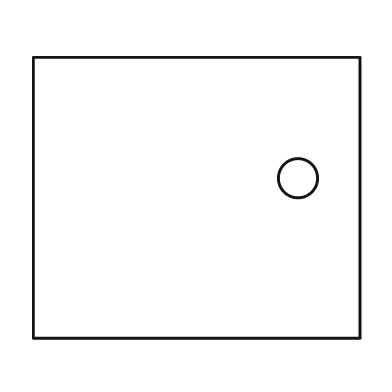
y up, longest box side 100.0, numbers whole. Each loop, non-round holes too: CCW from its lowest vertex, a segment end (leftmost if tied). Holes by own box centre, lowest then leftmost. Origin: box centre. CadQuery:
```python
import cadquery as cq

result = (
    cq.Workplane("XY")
    .moveTo(-50.0, -43.0)
    .lineTo(50.0, -43.0)
    .lineTo(50.0, 43.0)
    .lineTo(-50.0, 43.0)
    .close()
    .moveTo(31.0, 6.0)
    .circle(6.0)
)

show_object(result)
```